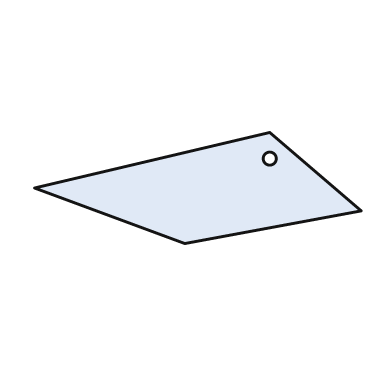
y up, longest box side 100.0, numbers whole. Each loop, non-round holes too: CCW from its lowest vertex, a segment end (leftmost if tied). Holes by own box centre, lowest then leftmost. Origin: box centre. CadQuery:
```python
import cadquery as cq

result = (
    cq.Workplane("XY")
    .moveTo(-4.0, -17.0)
    .lineTo(50.0, -7.0)
    .lineTo(22.0, 17.0)
    .lineTo(-50.0, 0.0)
    .close()
    .moveTo(22.0, 9.0)
    .circle(2.0)
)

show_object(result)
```